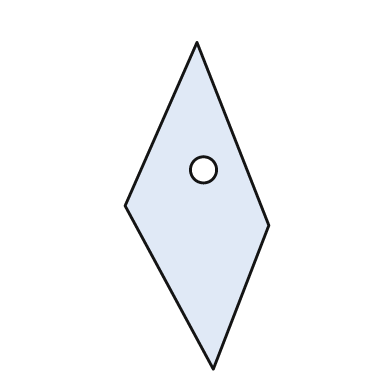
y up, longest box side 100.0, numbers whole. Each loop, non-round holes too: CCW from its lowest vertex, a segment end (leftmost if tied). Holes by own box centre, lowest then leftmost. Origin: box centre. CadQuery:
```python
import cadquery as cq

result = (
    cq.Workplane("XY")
    .moveTo(5.0, -50.0)
    .lineTo(22.0, -6.0)
    .lineTo(0.0, 50.0)
    .lineTo(-22.0, 0.0)
    .close()
    .moveTo(2.0, 11.0)
    .circle(4.0)
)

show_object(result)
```